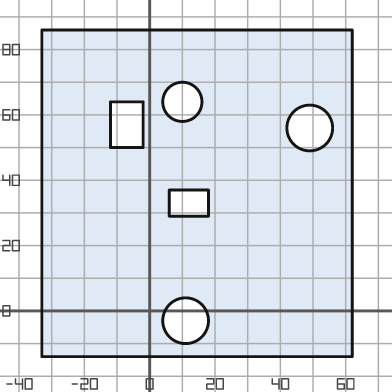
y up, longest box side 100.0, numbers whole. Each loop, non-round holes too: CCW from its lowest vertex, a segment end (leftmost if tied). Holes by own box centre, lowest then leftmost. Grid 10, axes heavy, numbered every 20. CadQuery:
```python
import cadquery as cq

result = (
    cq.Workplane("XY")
    .moveTo(-33.0, -14.0)
    .lineTo(62.0, -14.0)
    .lineTo(62.0, 86.0)
    .lineTo(-33.0, 86.0)
    .close()
    .moveTo(11.0, -3.0)
    .circle(7.0)
    .moveTo(6.0, 29.0)
    .lineTo(18.0, 29.0)
    .lineTo(18.0, 37.0)
    .lineTo(6.0, 37.0)
    .close()
    .moveTo(49.0, 56.0)
    .circle(7.0)
    .moveTo(-12.0, 50.0)
    .lineTo(-2.0, 50.0)
    .lineTo(-2.0, 64.0)
    .lineTo(-12.0, 64.0)
    .close()
    .moveTo(10.0, 64.0)
    .circle(6.0)
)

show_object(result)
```